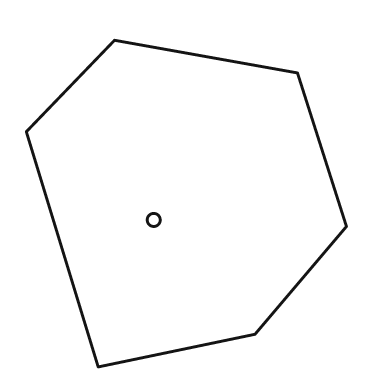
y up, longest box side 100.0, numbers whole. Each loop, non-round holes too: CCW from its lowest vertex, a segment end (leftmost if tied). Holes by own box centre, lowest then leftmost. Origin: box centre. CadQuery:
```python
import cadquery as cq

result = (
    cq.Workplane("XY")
    .moveTo(-27.0, -50.0)
    .lineTo(21.0, -40.0)
    .lineTo(49.0, -7.0)
    .lineTo(34.0, 40.0)
    .lineTo(-22.0, 50.0)
    .lineTo(-49.0, 22.0)
    .close()
    .moveTo(-10.0, -5.0)
    .circle(2.0)
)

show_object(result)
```